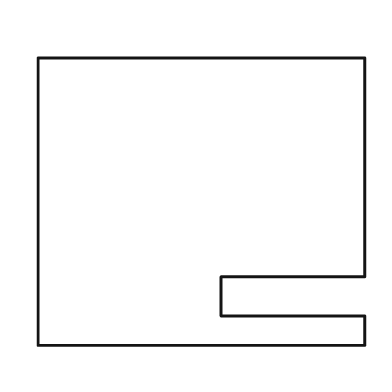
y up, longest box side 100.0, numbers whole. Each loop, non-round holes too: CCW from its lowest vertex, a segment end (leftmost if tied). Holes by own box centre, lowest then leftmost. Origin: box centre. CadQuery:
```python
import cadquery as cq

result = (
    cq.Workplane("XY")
    .moveTo(-50.0, -44.0)
    .lineTo(50.0, -44.0)
    .lineTo(50.0, -35.0)
    .lineTo(6.0, -35.0)
    .lineTo(6.0, -23.0)
    .lineTo(50.0, -23.0)
    .lineTo(50.0, 44.0)
    .lineTo(-50.0, 44.0)
    .close()
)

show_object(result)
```